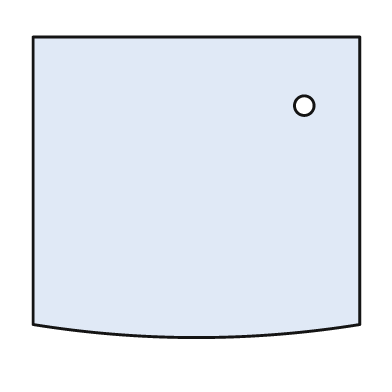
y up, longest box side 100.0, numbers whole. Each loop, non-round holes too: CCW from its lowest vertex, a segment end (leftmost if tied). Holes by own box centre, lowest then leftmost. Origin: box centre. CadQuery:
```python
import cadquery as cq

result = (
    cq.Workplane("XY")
    .moveTo(-50.0, -42.0)
    .threePointArc((0.0, -46.0), (50.0, -42.0))
    .lineTo(50.0, 46.0)
    .lineTo(-50.0, 46.0)
    .close()
    .moveTo(33.0, 25.0)
    .circle(3.0)
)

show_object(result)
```